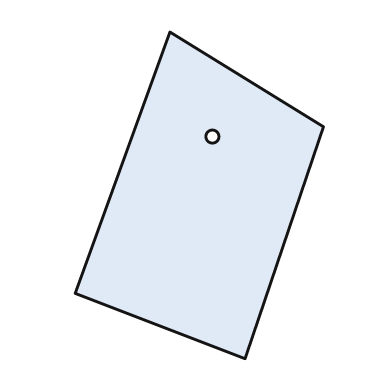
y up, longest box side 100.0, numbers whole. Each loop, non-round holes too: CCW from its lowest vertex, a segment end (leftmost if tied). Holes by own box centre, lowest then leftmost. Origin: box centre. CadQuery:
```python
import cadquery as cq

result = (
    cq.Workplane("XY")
    .moveTo(14.0, -50.0)
    .lineTo(38.0, 21.0)
    .lineTo(-9.0, 50.0)
    .lineTo(-38.0, -30.0)
    .close()
    .moveTo(4.0, 18.0)
    .circle(2.0)
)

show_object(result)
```